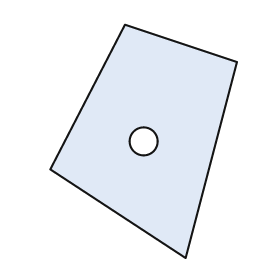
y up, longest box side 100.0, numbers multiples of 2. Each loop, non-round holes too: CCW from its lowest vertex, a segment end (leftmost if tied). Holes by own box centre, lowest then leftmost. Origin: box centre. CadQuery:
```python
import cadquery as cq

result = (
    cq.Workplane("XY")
    .moveTo(18.0, -50.0)
    .lineTo(40.0, 34.0)
    .lineTo(-8.0, 50.0)
    .lineTo(-40.0, -12.0)
    .close()
    .moveTo(0.0, 0.0)
    .circle(6.0)
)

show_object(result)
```